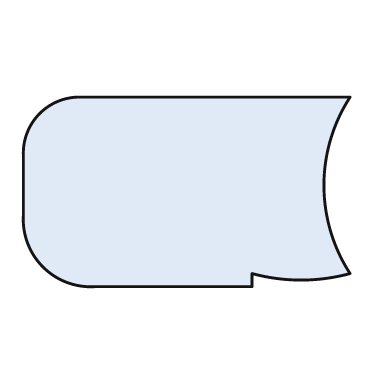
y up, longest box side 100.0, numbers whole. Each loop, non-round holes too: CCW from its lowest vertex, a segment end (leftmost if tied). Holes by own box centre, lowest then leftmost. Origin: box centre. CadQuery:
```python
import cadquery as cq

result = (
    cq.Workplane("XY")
    .moveTo(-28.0, -29.0)
    .lineTo(20.0, -29.0)
    .lineTo(20.0, -25.0)
    .threePointArc((35.0, -27.0), (50.0, -25.0))
    .threePointArc((42.0, 2.0), (50.0, 29.0))
    .lineTo(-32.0, 29.0)
    .threePointArc((-45.0, 24.0), (-50.0, 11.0))
    .lineTo(-50.0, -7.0)
    .threePointArc((-44.0, -23.0), (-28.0, -29.0))
    .close()
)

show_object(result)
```